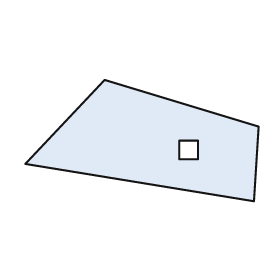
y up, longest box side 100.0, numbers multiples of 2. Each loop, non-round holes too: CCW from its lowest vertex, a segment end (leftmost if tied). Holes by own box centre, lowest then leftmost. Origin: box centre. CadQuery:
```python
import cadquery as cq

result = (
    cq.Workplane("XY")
    .moveTo(48.0, -26.0)
    .lineTo(50.0, 6.0)
    .lineTo(-16.0, 26.0)
    .lineTo(-50.0, -10.0)
    .close()
    .moveTo(16.0, -8.0)
    .lineTo(24.0, -8.0)
    .lineTo(24.0, 0.0)
    .lineTo(16.0, 0.0)
    .close()
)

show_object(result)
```